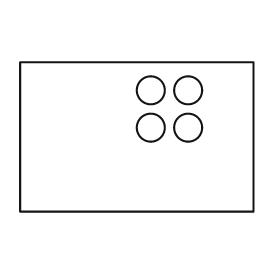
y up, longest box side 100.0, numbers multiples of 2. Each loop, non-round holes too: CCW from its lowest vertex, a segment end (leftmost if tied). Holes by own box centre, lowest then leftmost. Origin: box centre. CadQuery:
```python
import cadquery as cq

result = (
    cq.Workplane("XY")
    .moveTo(-50.0, -32.0)
    .lineTo(50.0, -32.0)
    .lineTo(50.0, 32.0)
    .lineTo(-50.0, 32.0)
    .close()
    .moveTo(6.0, 4.0)
    .circle(6.0)
    .moveTo(22.0, 4.0)
    .circle(6.0)
    .moveTo(6.0, 20.0)
    .circle(6.0)
    .moveTo(22.0, 20.0)
    .circle(6.0)
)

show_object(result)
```